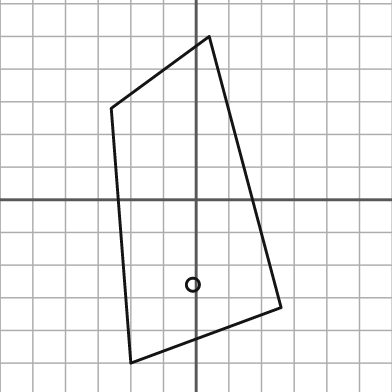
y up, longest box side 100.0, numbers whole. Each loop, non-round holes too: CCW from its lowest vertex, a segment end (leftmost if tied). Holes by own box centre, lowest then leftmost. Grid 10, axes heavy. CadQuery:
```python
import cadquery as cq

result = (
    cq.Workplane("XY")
    .moveTo(-20.0, -50.0)
    .lineTo(26.0, -33.0)
    .lineTo(4.0, 50.0)
    .lineTo(-26.0, 28.0)
    .close()
    .moveTo(-1.0, -26.0)
    .circle(2.0)
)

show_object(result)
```